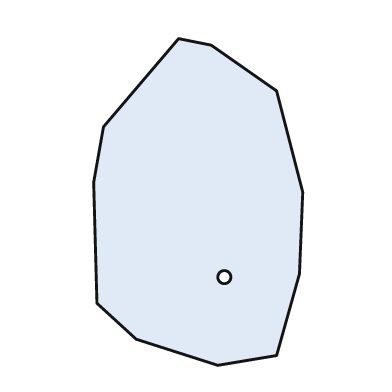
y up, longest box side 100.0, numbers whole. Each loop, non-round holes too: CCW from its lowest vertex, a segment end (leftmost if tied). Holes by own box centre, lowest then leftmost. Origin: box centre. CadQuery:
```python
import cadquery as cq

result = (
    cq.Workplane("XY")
    .moveTo(6.0, -50.0)
    .lineTo(24.0, -47.0)
    .lineTo(31.0, -22.0)
    .lineTo(32.0, 3.0)
    .lineTo(24.0, 34.0)
    .lineTo(4.0, 48.0)
    .lineTo(-6.0, 50.0)
    .lineTo(-29.0, 23.0)
    .lineTo(-32.0, 6.0)
    .lineTo(-31.0, -31.0)
    .lineTo(-19.0, -42.0)
    .close()
    .moveTo(8.0, -23.0)
    .circle(2.0)
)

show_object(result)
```